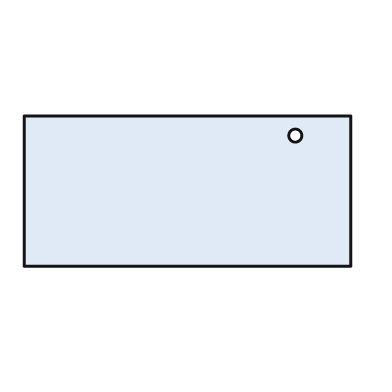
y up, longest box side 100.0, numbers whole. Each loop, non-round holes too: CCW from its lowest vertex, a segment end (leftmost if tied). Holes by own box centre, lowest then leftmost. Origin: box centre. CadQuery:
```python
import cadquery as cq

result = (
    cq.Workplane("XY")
    .moveTo(-50.0, -23.0)
    .lineTo(50.0, -23.0)
    .lineTo(50.0, 23.0)
    .lineTo(-50.0, 23.0)
    .close()
    .moveTo(33.0, 17.0)
    .circle(2.0)
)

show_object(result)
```